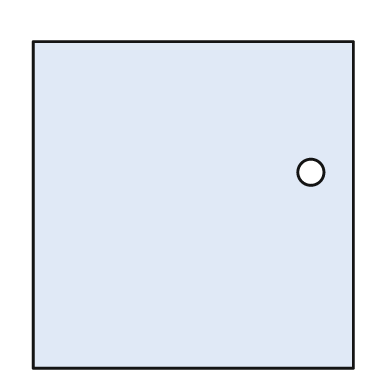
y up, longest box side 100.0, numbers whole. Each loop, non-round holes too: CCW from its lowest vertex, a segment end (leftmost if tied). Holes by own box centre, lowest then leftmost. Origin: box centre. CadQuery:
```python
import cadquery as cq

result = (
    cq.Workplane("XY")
    .moveTo(-49.0, -50.0)
    .lineTo(49.0, -50.0)
    .lineTo(49.0, 50.0)
    .lineTo(-49.0, 50.0)
    .close()
    .moveTo(36.0, 10.0)
    .circle(4.0)
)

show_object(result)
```